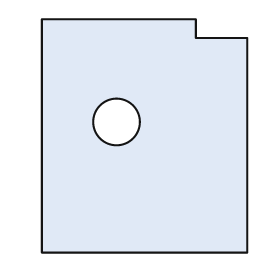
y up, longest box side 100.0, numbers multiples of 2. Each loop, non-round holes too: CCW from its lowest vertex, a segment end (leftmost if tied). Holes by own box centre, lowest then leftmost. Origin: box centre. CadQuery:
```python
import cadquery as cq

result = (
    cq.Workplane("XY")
    .moveTo(-44.0, -50.0)
    .lineTo(44.0, -50.0)
    .lineTo(44.0, 42.0)
    .lineTo(22.0, 42.0)
    .lineTo(22.0, 50.0)
    .lineTo(-44.0, 50.0)
    .close()
    .moveTo(-12.0, 6.0)
    .circle(10.0)
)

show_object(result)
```